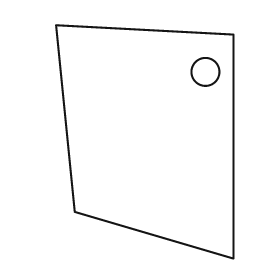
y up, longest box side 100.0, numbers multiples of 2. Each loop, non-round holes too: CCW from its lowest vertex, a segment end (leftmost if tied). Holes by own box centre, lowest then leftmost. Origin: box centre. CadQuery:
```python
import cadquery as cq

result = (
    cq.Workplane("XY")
    .moveTo(38.0, -50.0)
    .lineTo(38.0, 46.0)
    .lineTo(-38.0, 50.0)
    .lineTo(-30.0, -30.0)
    .close()
    .moveTo(26.0, 30.0)
    .circle(6.0)
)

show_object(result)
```